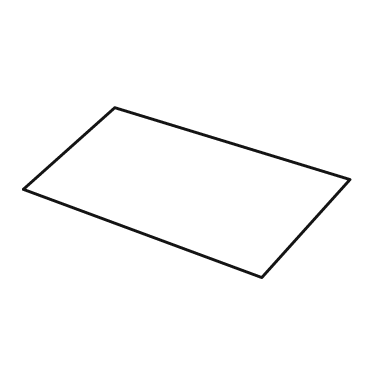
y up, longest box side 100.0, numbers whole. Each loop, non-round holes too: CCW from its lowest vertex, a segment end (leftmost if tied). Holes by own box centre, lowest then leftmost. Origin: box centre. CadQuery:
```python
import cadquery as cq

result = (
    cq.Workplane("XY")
    .moveTo(23.0, -26.0)
    .lineTo(50.0, 4.0)
    .lineTo(-22.0, 26.0)
    .lineTo(-50.0, 1.0)
    .close()
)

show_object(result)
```